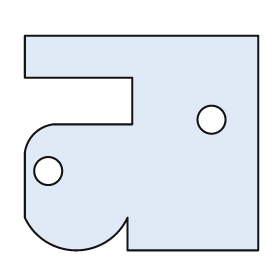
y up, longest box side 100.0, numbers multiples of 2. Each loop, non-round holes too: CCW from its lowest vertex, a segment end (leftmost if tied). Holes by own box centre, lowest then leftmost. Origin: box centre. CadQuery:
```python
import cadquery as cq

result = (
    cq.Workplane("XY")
    .moveTo(-6.0, -46.0)
    .lineTo(50.0, -46.0)
    .lineTo(50.0, 46.0)
    .lineTo(-50.0, 46.0)
    .lineTo(-50.0, 28.0)
    .lineTo(-4.0, 28.0)
    .lineTo(-4.0, 8.0)
    .lineTo(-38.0, 8.0)
    .threePointArc((-46.0, 4.0), (-50.0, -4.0))
    .lineTo(-50.0, -32.0)
    .threePointArc((-28.0, -46.0), (-6.0, -32.0))
    .close()
    .moveTo(-40.0, -12.0)
    .circle(6.0)
    .moveTo(30.0, 10.0)
    .circle(6.0)
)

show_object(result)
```